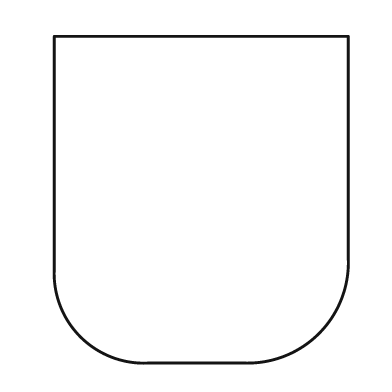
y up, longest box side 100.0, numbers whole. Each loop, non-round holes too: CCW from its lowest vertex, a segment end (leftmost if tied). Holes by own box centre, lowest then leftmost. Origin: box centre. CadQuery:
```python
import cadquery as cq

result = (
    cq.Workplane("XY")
    .moveTo(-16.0, -50.0)
    .lineTo(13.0, -50.0)
    .threePointArc((36.0, -41.0), (45.0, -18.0))
    .lineTo(45.0, 50.0)
    .lineTo(-45.0, 50.0)
    .lineTo(-45.0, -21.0)
    .threePointArc((-37.0, -42.0), (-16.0, -50.0))
    .close()
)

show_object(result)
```